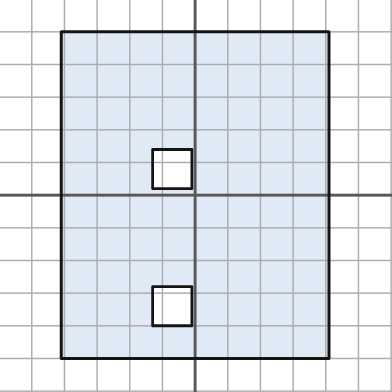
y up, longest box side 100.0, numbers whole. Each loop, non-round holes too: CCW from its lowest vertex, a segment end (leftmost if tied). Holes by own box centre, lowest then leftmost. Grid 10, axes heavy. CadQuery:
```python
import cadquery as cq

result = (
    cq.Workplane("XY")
    .moveTo(-41.0, -50.0)
    .lineTo(41.0, -50.0)
    .lineTo(41.0, 50.0)
    .lineTo(-41.0, 50.0)
    .close()
    .moveTo(-13.0, -40.0)
    .lineTo(-1.0, -40.0)
    .lineTo(-1.0, -28.0)
    .lineTo(-13.0, -28.0)
    .close()
    .moveTo(-13.0, 2.0)
    .lineTo(-1.0, 2.0)
    .lineTo(-1.0, 14.0)
    .lineTo(-13.0, 14.0)
    .close()
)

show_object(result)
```